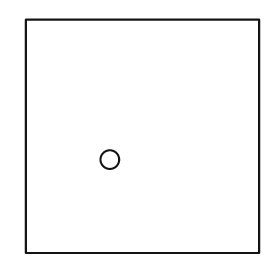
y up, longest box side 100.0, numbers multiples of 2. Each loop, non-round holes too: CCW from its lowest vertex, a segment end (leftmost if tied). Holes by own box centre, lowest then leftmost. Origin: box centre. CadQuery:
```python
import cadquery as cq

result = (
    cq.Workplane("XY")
    .moveTo(-50.0, -50.0)
    .lineTo(50.0, -50.0)
    .lineTo(50.0, 50.0)
    .lineTo(-50.0, 50.0)
    .close()
    .moveTo(-14.0, -10.0)
    .circle(4.0)
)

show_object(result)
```